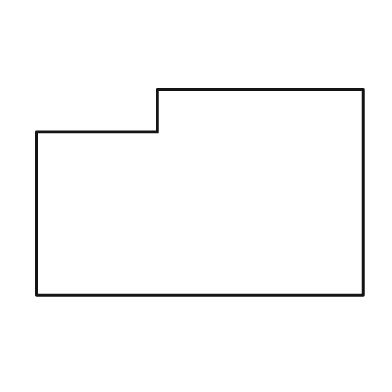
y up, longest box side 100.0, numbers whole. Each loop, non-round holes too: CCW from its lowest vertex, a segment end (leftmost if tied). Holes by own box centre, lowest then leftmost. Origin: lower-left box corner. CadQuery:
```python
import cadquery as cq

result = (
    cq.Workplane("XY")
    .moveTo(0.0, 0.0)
    .lineTo(100.0, 0.0)
    .lineTo(100.0, 63.0)
    .lineTo(37.0, 63.0)
    .lineTo(37.0, 50.0)
    .lineTo(0.0, 50.0)
    .close()
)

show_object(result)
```